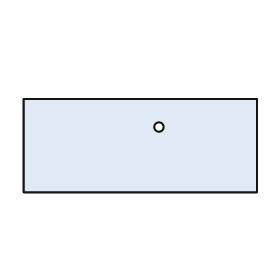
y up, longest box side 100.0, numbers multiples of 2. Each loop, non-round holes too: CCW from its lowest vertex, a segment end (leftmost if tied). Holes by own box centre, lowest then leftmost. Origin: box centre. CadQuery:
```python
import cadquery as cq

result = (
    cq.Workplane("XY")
    .moveTo(-50.0, -20.0)
    .lineTo(50.0, -20.0)
    .lineTo(50.0, 20.0)
    .lineTo(-50.0, 20.0)
    .close()
    .moveTo(8.0, 8.0)
    .circle(2.0)
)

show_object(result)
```